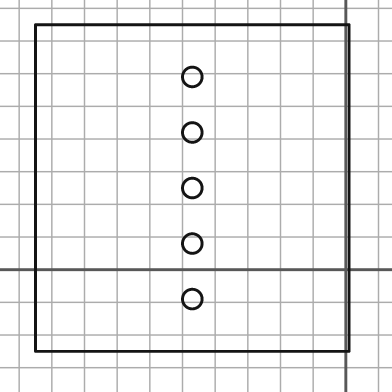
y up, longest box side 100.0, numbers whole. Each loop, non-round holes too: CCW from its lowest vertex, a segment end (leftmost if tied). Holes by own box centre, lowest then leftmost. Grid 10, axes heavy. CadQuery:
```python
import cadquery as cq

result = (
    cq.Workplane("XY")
    .moveTo(-95.0, -25.0)
    .lineTo(1.0, -25.0)
    .lineTo(1.0, 75.0)
    .lineTo(-95.0, 75.0)
    .close()
    .moveTo(-47.0, -9.0)
    .circle(3.0)
    .moveTo(-47.0, 8.0)
    .circle(3.0)
    .moveTo(-47.0, 25.0)
    .circle(3.0)
    .moveTo(-47.0, 42.0)
    .circle(3.0)
    .moveTo(-47.0, 59.0)
    .circle(3.0)
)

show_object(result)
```